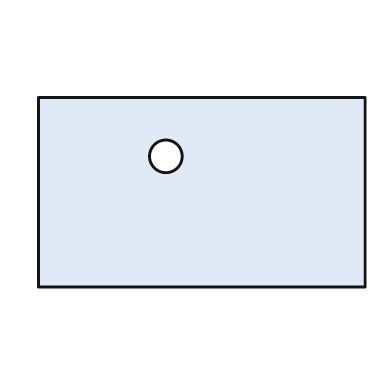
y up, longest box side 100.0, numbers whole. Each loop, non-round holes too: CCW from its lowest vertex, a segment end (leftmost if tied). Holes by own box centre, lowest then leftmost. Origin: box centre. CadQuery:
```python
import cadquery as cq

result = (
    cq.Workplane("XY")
    .moveTo(-50.0, -29.0)
    .lineTo(50.0, -29.0)
    .lineTo(50.0, 29.0)
    .lineTo(-50.0, 29.0)
    .close()
    .moveTo(-11.0, 11.0)
    .circle(5.0)
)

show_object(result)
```